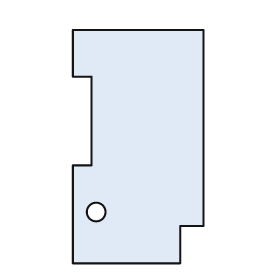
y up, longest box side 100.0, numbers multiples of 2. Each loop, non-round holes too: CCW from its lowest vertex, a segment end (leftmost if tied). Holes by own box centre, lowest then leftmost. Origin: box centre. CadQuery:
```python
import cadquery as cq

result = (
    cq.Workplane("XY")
    .moveTo(-28.0, -50.0)
    .lineTo(18.0, -50.0)
    .lineTo(18.0, -34.0)
    .lineTo(28.0, -34.0)
    .lineTo(28.0, 50.0)
    .lineTo(-28.0, 50.0)
    .lineTo(-28.0, 30.0)
    .lineTo(-20.0, 30.0)
    .lineTo(-20.0, -8.0)
    .lineTo(-28.0, -8.0)
    .close()
    .moveTo(-18.0, -28.0)
    .circle(4.0)
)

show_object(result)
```